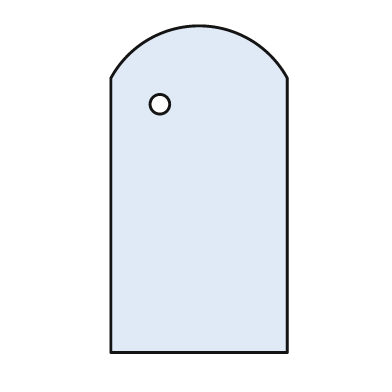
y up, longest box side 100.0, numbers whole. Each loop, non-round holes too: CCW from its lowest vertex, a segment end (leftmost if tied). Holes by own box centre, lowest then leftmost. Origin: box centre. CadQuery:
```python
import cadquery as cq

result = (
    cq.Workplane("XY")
    .moveTo(-27.0, -50.0)
    .lineTo(27.0, -50.0)
    .lineTo(27.0, 34.0)
    .threePointArc((0.0, 50.0), (-27.0, 34.0))
    .close()
    .moveTo(-12.0, 26.0)
    .circle(3.0)
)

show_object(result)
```